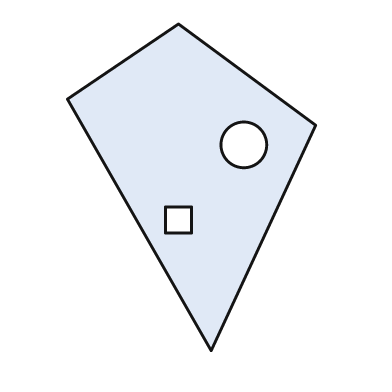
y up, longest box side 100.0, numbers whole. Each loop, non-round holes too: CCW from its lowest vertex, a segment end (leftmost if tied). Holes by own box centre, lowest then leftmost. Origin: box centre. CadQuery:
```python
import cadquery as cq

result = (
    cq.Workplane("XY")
    .moveTo(6.0, -50.0)
    .lineTo(38.0, 19.0)
    .lineTo(-4.0, 50.0)
    .lineTo(-38.0, 27.0)
    .close()
    .moveTo(-8.0, -14.0)
    .lineTo(0.0, -14.0)
    .lineTo(0.0, -6.0)
    .lineTo(-8.0, -6.0)
    .close()
    .moveTo(16.0, 13.0)
    .circle(7.0)
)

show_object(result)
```